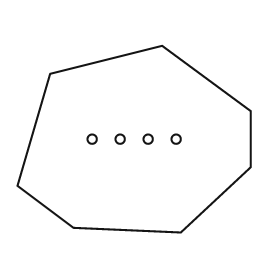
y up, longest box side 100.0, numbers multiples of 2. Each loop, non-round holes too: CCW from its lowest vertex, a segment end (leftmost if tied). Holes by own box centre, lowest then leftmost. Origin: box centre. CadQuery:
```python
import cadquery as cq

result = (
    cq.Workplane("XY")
    .moveTo(20.0, -40.0)
    .lineTo(50.0, -12.0)
    .lineTo(50.0, 12.0)
    .lineTo(12.0, 40.0)
    .lineTo(-36.0, 28.0)
    .lineTo(-50.0, -20.0)
    .lineTo(-26.0, -38.0)
    .close()
    .moveTo(-18.0, 0.0)
    .circle(2.0)
    .moveTo(-6.0, 0.0)
    .circle(2.0)
    .moveTo(6.0, 0.0)
    .circle(2.0)
    .moveTo(18.0, 0.0)
    .circle(2.0)
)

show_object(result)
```